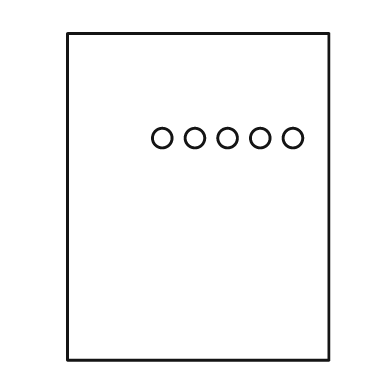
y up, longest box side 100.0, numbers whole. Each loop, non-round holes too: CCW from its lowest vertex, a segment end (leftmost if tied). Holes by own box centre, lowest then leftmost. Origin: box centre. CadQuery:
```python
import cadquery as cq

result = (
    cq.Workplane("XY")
    .moveTo(-40.0, -50.0)
    .lineTo(40.0, -50.0)
    .lineTo(40.0, 50.0)
    .lineTo(-40.0, 50.0)
    .close()
    .moveTo(-11.0, 18.0)
    .circle(3.0)
    .moveTo(-1.0, 18.0)
    .circle(3.0)
    .moveTo(9.0, 18.0)
    .circle(3.0)
    .moveTo(19.0, 18.0)
    .circle(3.0)
    .moveTo(29.0, 18.0)
    .circle(3.0)
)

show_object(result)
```